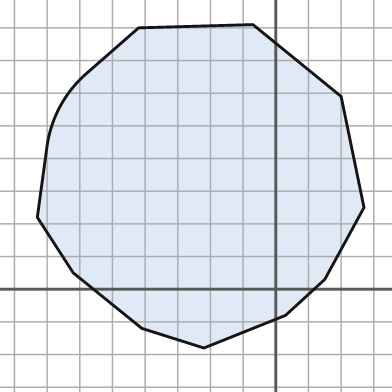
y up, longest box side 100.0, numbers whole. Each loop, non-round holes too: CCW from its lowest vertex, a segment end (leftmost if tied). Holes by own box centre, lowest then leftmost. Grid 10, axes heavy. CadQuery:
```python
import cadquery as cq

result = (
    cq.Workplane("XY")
    .moveTo(-22.0, -18.0)
    .lineTo(3.0, -8.0)
    .lineTo(15.0, 3.0)
    .lineTo(27.0, 25.0)
    .lineTo(20.0, 59.0)
    .lineTo(-7.0, 81.0)
    .lineTo(-42.0, 80.0)
    .lineTo(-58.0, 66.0)
    .threePointArc((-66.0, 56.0), (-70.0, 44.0))
    .lineTo(-73.0, 22.0)
    .lineTo(-62.0, 5.0)
    .lineTo(-41.0, -12.0)
    .close()
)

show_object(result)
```